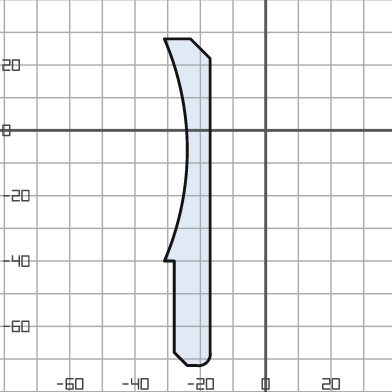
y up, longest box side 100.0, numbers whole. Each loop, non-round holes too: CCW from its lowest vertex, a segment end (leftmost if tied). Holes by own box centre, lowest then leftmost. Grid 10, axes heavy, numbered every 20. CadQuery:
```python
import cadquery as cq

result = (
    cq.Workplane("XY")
    .moveTo(-24.0, -72.0)
    .lineTo(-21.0, -72.0)
    .threePointArc((-18.0, -71.0), (-17.0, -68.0))
    .lineTo(-17.0, 22.0)
    .lineTo(-23.0, 28.0)
    .lineTo(-31.0, 28.0)
    .threePointArc((-24.0, -6.0), (-31.0, -40.0))
    .lineTo(-28.0, -40.0)
    .lineTo(-28.0, -68.0)
    .close()
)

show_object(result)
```